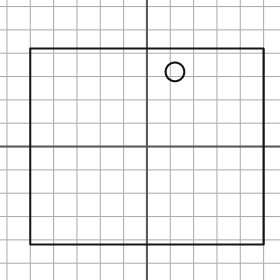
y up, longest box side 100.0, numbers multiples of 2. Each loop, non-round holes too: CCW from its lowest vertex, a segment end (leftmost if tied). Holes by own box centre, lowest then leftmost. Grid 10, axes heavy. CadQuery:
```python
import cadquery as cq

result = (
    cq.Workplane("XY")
    .moveTo(-50.0, -42.0)
    .lineTo(50.0, -42.0)
    .lineTo(50.0, 42.0)
    .lineTo(-50.0, 42.0)
    .close()
    .moveTo(12.0, 32.0)
    .circle(4.0)
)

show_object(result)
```